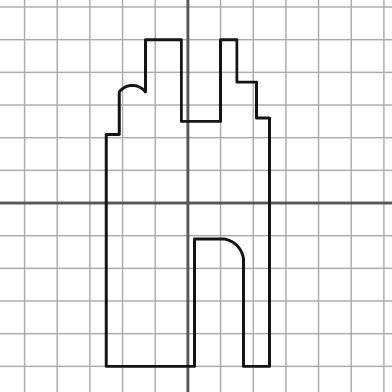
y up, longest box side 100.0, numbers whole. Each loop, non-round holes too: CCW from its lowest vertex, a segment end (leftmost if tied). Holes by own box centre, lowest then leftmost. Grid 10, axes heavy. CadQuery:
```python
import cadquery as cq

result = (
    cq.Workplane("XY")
    .moveTo(-25.0, -50.0)
    .lineTo(2.0, -50.0)
    .lineTo(2.0, -11.0)
    .lineTo(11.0, -11.0)
    .threePointArc((15.0, -13.0), (17.0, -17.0))
    .lineTo(17.0, -50.0)
    .lineTo(25.0, -50.0)
    .lineTo(25.0, 26.0)
    .lineTo(21.0, 26.0)
    .lineTo(21.0, 37.0)
    .lineTo(15.0, 37.0)
    .lineTo(15.0, 50.0)
    .lineTo(10.0, 50.0)
    .lineTo(10.0, 25.0)
    .lineTo(-2.0, 25.0)
    .lineTo(-2.0, 50.0)
    .lineTo(-13.0, 50.0)
    .lineTo(-13.0, 34.0)
    .threePointArc((-17.0, 36.0), (-21.0, 34.0))
    .lineTo(-21.0, 21.0)
    .lineTo(-25.0, 21.0)
    .close()
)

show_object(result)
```